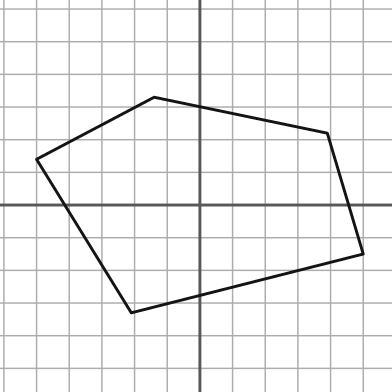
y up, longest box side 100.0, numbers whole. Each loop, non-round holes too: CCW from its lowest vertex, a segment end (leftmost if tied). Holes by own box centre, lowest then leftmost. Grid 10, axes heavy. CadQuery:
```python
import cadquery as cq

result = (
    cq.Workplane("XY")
    .moveTo(-21.0, -33.0)
    .lineTo(50.0, -15.0)
    .lineTo(39.0, 22.0)
    .lineTo(-14.0, 33.0)
    .lineTo(-50.0, 14.0)
    .close()
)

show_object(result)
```